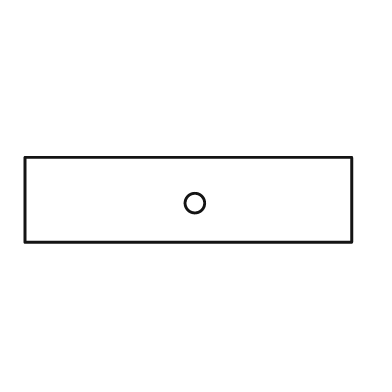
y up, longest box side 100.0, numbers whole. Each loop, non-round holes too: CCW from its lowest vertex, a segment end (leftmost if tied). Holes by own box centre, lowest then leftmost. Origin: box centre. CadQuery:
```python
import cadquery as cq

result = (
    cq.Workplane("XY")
    .moveTo(-50.0, -13.0)
    .lineTo(50.0, -13.0)
    .lineTo(50.0, 13.0)
    .lineTo(-50.0, 13.0)
    .close()
    .moveTo(2.0, -1.0)
    .circle(3.0)
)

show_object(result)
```